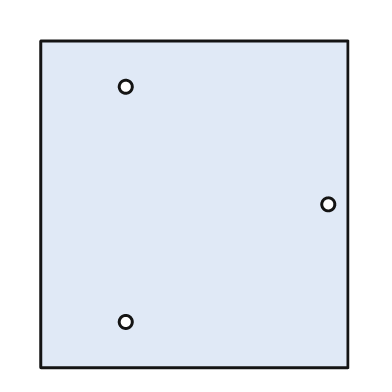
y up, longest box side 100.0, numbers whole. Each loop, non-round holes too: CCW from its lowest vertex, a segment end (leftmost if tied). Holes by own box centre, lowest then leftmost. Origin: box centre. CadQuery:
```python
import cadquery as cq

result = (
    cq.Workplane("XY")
    .moveTo(-47.0, -50.0)
    .lineTo(47.0, -50.0)
    .lineTo(47.0, 50.0)
    .lineTo(-47.0, 50.0)
    .close()
    .moveTo(-21.0, -36.0)
    .circle(2.0)
    .moveTo(41.0, 0.0)
    .circle(2.0)
    .moveTo(-21.0, 36.0)
    .circle(2.0)
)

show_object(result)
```